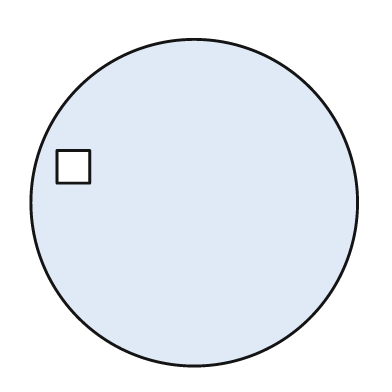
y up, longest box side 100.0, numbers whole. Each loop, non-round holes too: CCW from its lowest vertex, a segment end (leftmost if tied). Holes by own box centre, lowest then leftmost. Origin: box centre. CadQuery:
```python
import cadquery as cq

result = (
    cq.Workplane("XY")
    .moveTo(0.0, 0.0)
    .circle(50.0)
    .moveTo(-42.0, 6.0)
    .lineTo(-32.0, 6.0)
    .lineTo(-32.0, 16.0)
    .lineTo(-42.0, 16.0)
    .close()
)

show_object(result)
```